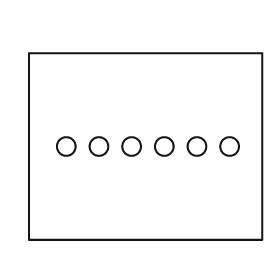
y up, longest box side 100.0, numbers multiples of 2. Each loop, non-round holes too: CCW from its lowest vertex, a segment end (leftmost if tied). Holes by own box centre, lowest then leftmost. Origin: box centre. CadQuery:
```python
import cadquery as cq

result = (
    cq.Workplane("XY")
    .moveTo(-50.0, -40.0)
    .lineTo(50.0, -40.0)
    .lineTo(50.0, 40.0)
    .lineTo(-50.0, 40.0)
    .close()
    .moveTo(-34.0, 0.0)
    .circle(4.0)
    .moveTo(-20.0, 0.0)
    .circle(4.0)
    .moveTo(-6.0, 0.0)
    .circle(4.0)
    .moveTo(8.0, 0.0)
    .circle(4.0)
    .moveTo(22.0, 0.0)
    .circle(4.0)
    .moveTo(36.0, 0.0)
    .circle(4.0)
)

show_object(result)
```